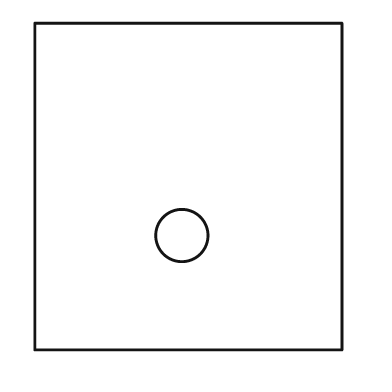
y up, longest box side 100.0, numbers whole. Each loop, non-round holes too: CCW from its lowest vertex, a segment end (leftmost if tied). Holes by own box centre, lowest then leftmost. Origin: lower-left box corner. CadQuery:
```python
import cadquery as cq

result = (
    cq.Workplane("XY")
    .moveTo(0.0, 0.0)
    .lineTo(94.0, 0.0)
    .lineTo(94.0, 100.0)
    .lineTo(0.0, 100.0)
    .close()
    .moveTo(45.0, 35.0)
    .circle(8.0)
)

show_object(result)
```